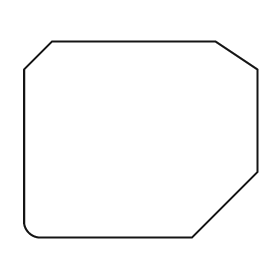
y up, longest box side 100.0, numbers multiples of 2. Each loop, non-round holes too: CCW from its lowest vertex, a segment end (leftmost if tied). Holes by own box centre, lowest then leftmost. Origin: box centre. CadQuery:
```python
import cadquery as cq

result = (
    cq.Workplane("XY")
    .moveTo(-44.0, -42.0)
    .lineTo(22.0, -42.0)
    .lineTo(50.0, -14.0)
    .lineTo(50.0, 30.0)
    .lineTo(32.0, 42.0)
    .lineTo(-38.0, 42.0)
    .lineTo(-50.0, 30.0)
    .lineTo(-50.0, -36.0)
    .threePointArc((-48.0, -40.0), (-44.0, -42.0))
    .close()
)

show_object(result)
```